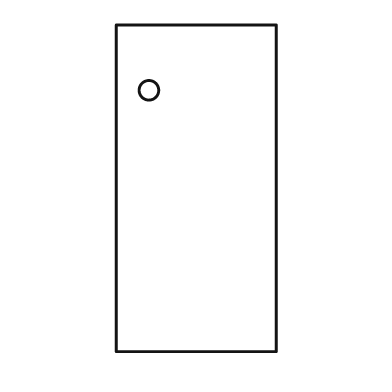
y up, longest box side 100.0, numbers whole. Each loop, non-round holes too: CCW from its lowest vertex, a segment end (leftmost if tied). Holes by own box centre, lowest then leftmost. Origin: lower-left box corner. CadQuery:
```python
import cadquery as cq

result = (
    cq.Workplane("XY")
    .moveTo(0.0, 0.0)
    .lineTo(49.0, 0.0)
    .lineTo(49.0, 100.0)
    .lineTo(0.0, 100.0)
    .close()
    .moveTo(10.0, 80.0)
    .circle(3.0)
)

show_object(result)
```